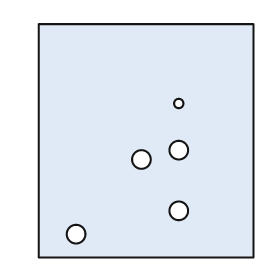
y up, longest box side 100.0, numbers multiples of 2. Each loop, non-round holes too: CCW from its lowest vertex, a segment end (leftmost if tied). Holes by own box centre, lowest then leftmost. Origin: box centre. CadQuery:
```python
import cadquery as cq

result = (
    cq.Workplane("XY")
    .moveTo(-46.0, -50.0)
    .lineTo(46.0, -50.0)
    .lineTo(46.0, 50.0)
    .lineTo(-46.0, 50.0)
    .close()
    .moveTo(-30.0, -40.0)
    .circle(4.0)
    .moveTo(14.0, -30.0)
    .circle(4.0)
    .moveTo(-2.0, -8.0)
    .circle(4.0)
    .moveTo(14.0, -4.0)
    .circle(4.0)
    .moveTo(14.0, 16.0)
    .circle(2.0)
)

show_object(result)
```